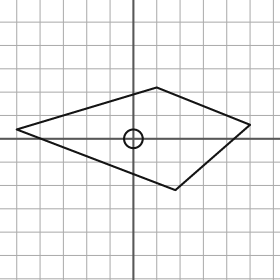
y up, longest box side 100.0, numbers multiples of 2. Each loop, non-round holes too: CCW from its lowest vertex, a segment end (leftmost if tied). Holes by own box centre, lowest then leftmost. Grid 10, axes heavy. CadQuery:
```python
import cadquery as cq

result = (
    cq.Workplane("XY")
    .moveTo(18.0, -22.0)
    .lineTo(50.0, 6.0)
    .lineTo(10.0, 22.0)
    .lineTo(-50.0, 4.0)
    .close()
    .moveTo(0.0, 0.0)
    .circle(4.0)
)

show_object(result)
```